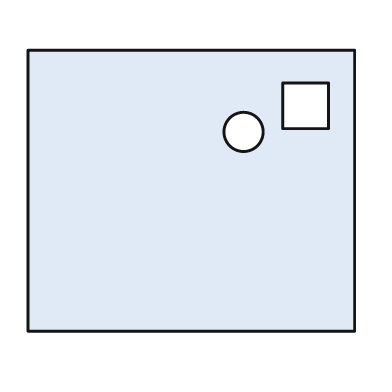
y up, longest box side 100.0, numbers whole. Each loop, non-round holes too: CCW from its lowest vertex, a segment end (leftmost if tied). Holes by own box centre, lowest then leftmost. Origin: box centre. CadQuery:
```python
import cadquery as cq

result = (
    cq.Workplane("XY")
    .moveTo(-50.0, -43.0)
    .lineTo(50.0, -43.0)
    .lineTo(50.0, 43.0)
    .lineTo(-50.0, 43.0)
    .close()
    .moveTo(16.0, 18.0)
    .circle(6.0)
    .moveTo(28.0, 19.0)
    .lineTo(42.0, 19.0)
    .lineTo(42.0, 33.0)
    .lineTo(28.0, 33.0)
    .close()
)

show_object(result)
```